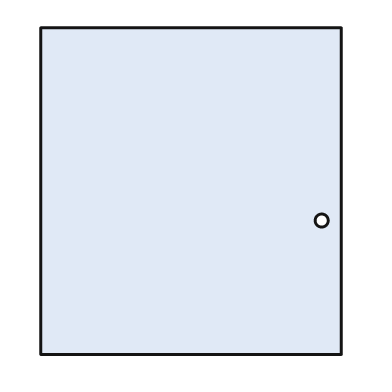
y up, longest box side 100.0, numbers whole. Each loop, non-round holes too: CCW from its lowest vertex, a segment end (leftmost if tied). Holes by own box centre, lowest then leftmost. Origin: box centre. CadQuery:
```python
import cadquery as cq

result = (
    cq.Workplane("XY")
    .moveTo(-46.0, -50.0)
    .lineTo(46.0, -50.0)
    .lineTo(46.0, 50.0)
    .lineTo(-46.0, 50.0)
    .close()
    .moveTo(40.0, -9.0)
    .circle(2.0)
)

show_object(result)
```